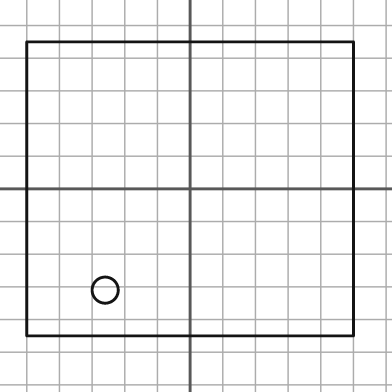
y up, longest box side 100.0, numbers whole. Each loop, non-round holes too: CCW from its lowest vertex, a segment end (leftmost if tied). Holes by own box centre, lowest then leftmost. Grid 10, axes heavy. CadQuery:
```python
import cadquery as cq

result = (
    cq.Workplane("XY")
    .moveTo(-50.0, -45.0)
    .lineTo(50.0, -45.0)
    .lineTo(50.0, 45.0)
    .lineTo(-50.0, 45.0)
    .close()
    .moveTo(-26.0, -31.0)
    .circle(4.0)
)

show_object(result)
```